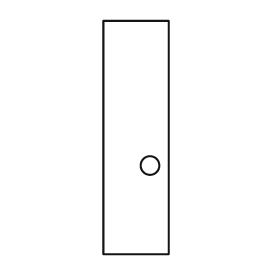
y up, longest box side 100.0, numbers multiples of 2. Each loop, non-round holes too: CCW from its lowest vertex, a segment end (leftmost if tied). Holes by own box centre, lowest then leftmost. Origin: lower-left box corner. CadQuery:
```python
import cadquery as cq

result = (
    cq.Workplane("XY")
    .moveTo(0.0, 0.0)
    .lineTo(28.0, 0.0)
    .lineTo(28.0, 100.0)
    .lineTo(0.0, 100.0)
    .close()
    .moveTo(20.0, 38.0)
    .circle(4.0)
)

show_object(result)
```